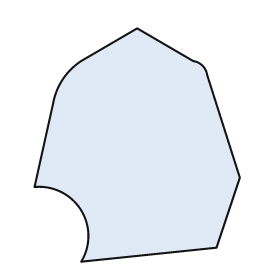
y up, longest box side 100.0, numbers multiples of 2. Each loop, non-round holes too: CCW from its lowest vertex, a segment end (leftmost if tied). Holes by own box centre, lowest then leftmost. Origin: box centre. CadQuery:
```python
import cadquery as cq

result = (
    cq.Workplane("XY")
    .moveTo(-24.0, -50.0)
    .lineTo(34.0, -44.0)
    .lineTo(44.0, -14.0)
    .lineTo(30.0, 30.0)
    .threePointArc((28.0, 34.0), (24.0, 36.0))
    .lineTo(0.0, 50.0)
    .lineTo(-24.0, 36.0)
    .threePointArc((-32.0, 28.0), (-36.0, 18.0))
    .lineTo(-44.0, -18.0)
    .threePointArc((-24.0, -28.0), (-24.0, -50.0))
    .close()
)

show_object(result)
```